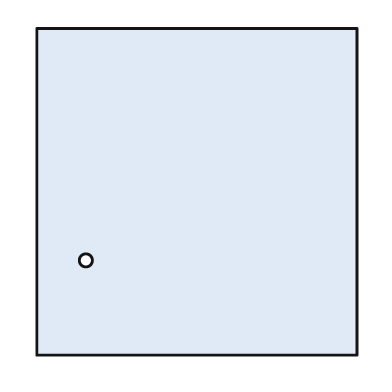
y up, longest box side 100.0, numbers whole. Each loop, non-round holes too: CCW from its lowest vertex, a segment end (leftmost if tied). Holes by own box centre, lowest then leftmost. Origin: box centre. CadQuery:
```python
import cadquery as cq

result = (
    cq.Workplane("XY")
    .moveTo(-49.0, -50.0)
    .lineTo(49.0, -50.0)
    .lineTo(49.0, 50.0)
    .lineTo(-49.0, 50.0)
    .close()
    .moveTo(-34.0, -21.0)
    .circle(2.0)
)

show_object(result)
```